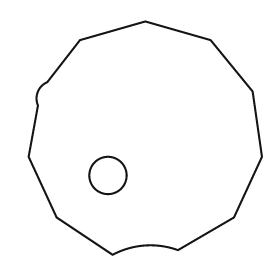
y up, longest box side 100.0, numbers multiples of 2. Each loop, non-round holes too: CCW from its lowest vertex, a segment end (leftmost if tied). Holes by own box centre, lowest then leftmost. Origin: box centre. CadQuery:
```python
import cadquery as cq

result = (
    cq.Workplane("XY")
    .moveTo(-14.0, -50.0)
    .threePointArc((0.0, -46.0), (14.0, -48.0))
    .lineTo(38.0, -34.0)
    .lineTo(50.0, -8.0)
    .lineTo(46.0, 20.0)
    .lineTo(28.0, 42.0)
    .lineTo(0.0, 50.0)
    .lineTo(-28.0, 42.0)
    .lineTo(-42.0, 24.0)
    .threePointArc((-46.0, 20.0), (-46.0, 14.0))
    .lineTo(-50.0, -8.0)
    .lineTo(-38.0, -34.0)
    .close()
    .moveTo(-16.0, -16.0)
    .circle(8.0)
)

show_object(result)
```